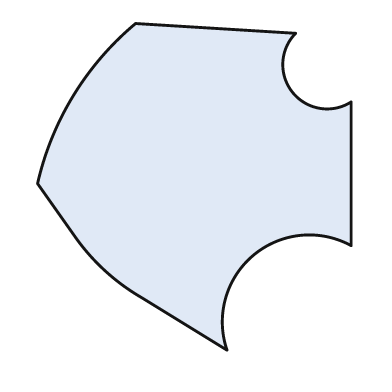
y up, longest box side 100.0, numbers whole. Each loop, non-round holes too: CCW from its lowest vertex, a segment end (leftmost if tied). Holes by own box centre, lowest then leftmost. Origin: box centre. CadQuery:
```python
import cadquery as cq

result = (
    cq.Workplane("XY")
    .moveTo(10.0, -50.0)
    .threePointArc((18.0, -21.0), (48.0, -18.0))
    .lineTo(48.0, 26.0)
    .threePointArc((30.0, 29.0), (31.0, 47.0))
    .lineTo(-18.0, 50.0)
    .threePointArc((-37.0, 28.0), (-48.0, 1.0))
    .lineTo(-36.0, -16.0)
    .threePointArc((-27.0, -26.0), (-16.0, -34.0))
    .close()
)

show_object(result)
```